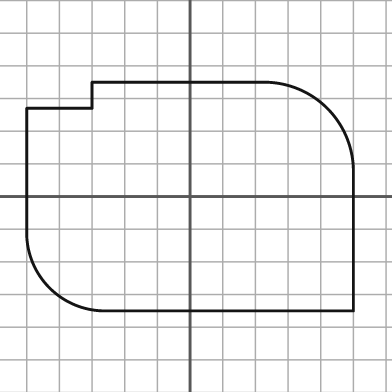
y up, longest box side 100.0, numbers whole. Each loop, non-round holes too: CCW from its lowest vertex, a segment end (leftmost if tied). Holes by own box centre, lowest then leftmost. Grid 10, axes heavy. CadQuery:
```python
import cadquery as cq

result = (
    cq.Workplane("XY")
    .moveTo(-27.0, -35.0)
    .lineTo(50.0, -35.0)
    .lineTo(50.0, 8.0)
    .threePointArc((42.0, 27.0), (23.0, 35.0))
    .lineTo(-30.0, 35.0)
    .lineTo(-30.0, 27.0)
    .lineTo(-50.0, 27.0)
    .lineTo(-50.0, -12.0)
    .threePointArc((-43.0, -28.0), (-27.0, -35.0))
    .close()
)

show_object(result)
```